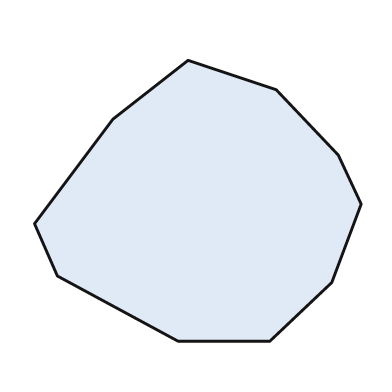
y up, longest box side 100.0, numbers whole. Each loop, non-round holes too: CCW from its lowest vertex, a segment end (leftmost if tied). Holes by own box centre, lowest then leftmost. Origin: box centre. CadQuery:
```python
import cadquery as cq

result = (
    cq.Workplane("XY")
    .moveTo(-6.0, -43.0)
    .lineTo(22.0, -43.0)
    .lineTo(41.0, -25.0)
    .lineTo(50.0, -1.0)
    .lineTo(43.0, 14.0)
    .lineTo(24.0, 34.0)
    .lineTo(-3.0, 43.0)
    .lineTo(-26.0, 25.0)
    .lineTo(-50.0, -7.0)
    .lineTo(-43.0, -23.0)
    .close()
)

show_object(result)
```